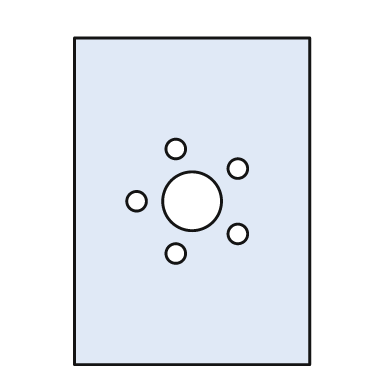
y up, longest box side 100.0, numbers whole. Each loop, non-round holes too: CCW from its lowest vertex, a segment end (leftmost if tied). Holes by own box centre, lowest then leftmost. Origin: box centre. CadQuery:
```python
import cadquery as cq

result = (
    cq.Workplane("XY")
    .moveTo(-36.0, -50.0)
    .lineTo(36.0, -50.0)
    .lineTo(36.0, 50.0)
    .lineTo(-36.0, 50.0)
    .close()
    .moveTo(-5.0, -16.0)
    .circle(3.0)
    .moveTo(14.0, -10.0)
    .circle(3.0)
    .moveTo(-17.0, 0.0)
    .circle(3.0)
    .moveTo(0.0, 0.0)
    .circle(9.0)
    .moveTo(14.0, 10.0)
    .circle(3.0)
    .moveTo(-5.0, 16.0)
    .circle(3.0)
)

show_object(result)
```